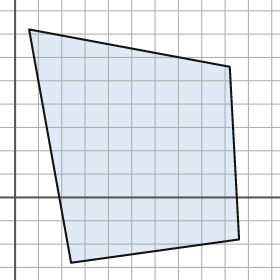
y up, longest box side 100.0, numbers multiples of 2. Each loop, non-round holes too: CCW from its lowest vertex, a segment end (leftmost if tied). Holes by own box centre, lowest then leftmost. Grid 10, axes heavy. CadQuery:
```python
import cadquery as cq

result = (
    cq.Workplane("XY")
    .moveTo(24.0, -28.0)
    .lineTo(96.0, -18.0)
    .lineTo(92.0, 56.0)
    .lineTo(6.0, 72.0)
    .close()
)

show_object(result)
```